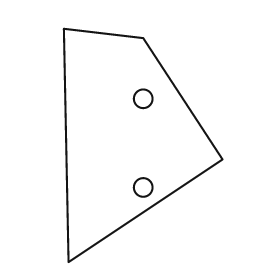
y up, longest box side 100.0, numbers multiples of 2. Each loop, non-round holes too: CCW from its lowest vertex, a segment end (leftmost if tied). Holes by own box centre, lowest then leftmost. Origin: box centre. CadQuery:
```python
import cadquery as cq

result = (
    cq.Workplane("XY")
    .moveTo(-32.0, -50.0)
    .lineTo(34.0, -6.0)
    .lineTo(0.0, 46.0)
    .lineTo(-34.0, 50.0)
    .close()
    .moveTo(0.0, -18.0)
    .circle(4.0)
    .moveTo(0.0, 20.0)
    .circle(4.0)
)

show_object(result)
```